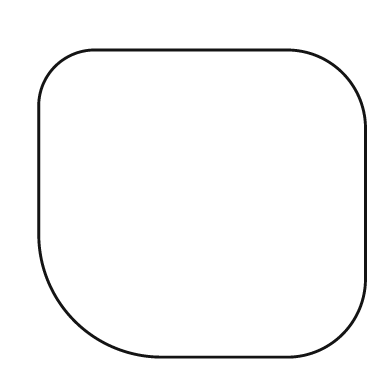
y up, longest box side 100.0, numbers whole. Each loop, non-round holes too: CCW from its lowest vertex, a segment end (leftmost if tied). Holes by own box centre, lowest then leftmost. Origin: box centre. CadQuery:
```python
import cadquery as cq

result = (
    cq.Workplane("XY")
    .moveTo(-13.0, -47.0)
    .lineTo(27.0, -47.0)
    .threePointArc((43.0, -40.0), (50.0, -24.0))
    .lineTo(50.0, 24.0)
    .threePointArc((43.0, 40.0), (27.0, 47.0))
    .lineTo(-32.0, 47.0)
    .threePointArc((-45.0, 42.0), (-50.0, 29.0))
    .lineTo(-50.0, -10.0)
    .threePointArc((-39.0, -36.0), (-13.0, -47.0))
    .close()
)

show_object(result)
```